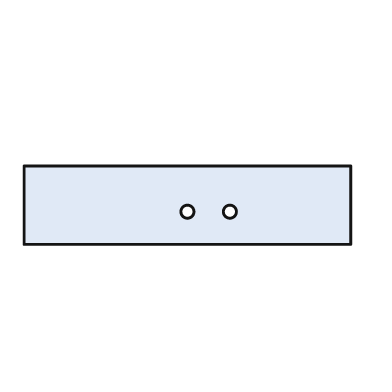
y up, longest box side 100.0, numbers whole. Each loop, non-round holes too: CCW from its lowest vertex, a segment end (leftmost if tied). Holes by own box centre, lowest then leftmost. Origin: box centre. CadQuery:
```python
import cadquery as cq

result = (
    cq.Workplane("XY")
    .moveTo(-50.0, -12.0)
    .lineTo(50.0, -12.0)
    .lineTo(50.0, 12.0)
    .lineTo(-50.0, 12.0)
    .close()
    .moveTo(0.0, -2.0)
    .circle(2.0)
    .moveTo(13.0, -2.0)
    .circle(2.0)
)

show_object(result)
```